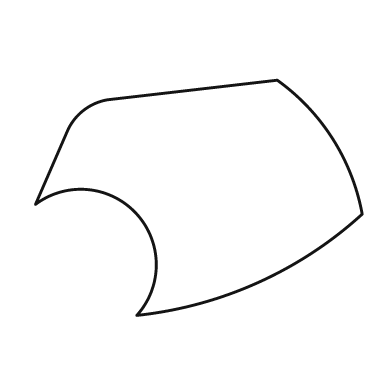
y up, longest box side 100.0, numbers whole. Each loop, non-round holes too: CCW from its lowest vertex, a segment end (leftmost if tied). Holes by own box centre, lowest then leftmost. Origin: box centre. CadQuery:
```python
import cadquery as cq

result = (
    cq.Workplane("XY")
    .moveTo(-19.0, -36.0)
    .threePointArc((18.0, -26.0), (50.0, -5.0))
    .threePointArc((41.0, 18.0), (24.0, 36.0))
    .lineTo(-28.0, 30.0)
    .threePointArc((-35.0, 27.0), (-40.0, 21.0))
    .lineTo(-50.0, -2.0)
    .threePointArc((-19.0, -5.0), (-19.0, -36.0))
    .close()
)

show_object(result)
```